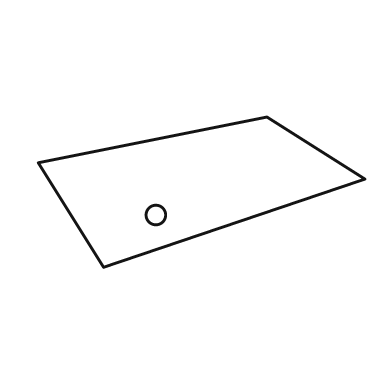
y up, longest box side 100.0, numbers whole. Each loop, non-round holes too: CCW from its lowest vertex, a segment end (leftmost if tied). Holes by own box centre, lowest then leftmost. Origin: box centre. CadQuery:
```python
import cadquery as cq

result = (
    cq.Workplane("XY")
    .moveTo(-30.0, -23.0)
    .lineTo(50.0, 4.0)
    .lineTo(20.0, 23.0)
    .lineTo(-50.0, 9.0)
    .close()
    .moveTo(-14.0, -7.0)
    .circle(3.0)
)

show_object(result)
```